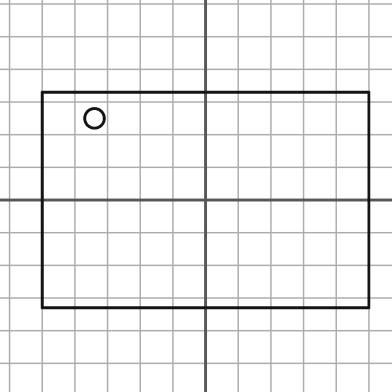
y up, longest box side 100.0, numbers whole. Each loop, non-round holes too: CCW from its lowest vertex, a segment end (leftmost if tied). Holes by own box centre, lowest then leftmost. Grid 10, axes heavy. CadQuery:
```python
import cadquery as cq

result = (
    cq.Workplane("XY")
    .moveTo(-50.0, -33.0)
    .lineTo(50.0, -33.0)
    .lineTo(50.0, 33.0)
    .lineTo(-50.0, 33.0)
    .close()
    .moveTo(-34.0, 25.0)
    .circle(3.0)
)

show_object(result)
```